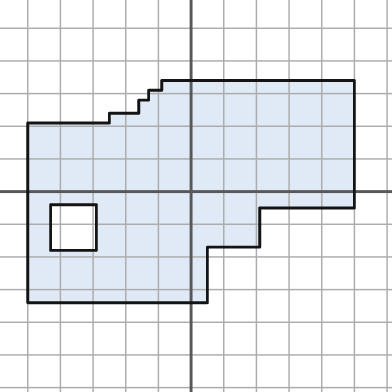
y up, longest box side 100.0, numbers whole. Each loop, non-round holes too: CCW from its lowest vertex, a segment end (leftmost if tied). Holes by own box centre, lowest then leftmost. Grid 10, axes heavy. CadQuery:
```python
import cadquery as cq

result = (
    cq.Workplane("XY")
    .moveTo(-50.0, -34.0)
    .lineTo(5.0, -34.0)
    .lineTo(5.0, -17.0)
    .lineTo(21.0, -17.0)
    .lineTo(21.0, -5.0)
    .lineTo(50.0, -5.0)
    .lineTo(50.0, 34.0)
    .lineTo(-9.0, 34.0)
    .lineTo(-9.0, 31.0)
    .lineTo(-13.0, 31.0)
    .lineTo(-13.0, 28.0)
    .lineTo(-16.0, 28.0)
    .lineTo(-16.0, 24.0)
    .lineTo(-25.0, 24.0)
    .lineTo(-25.0, 21.0)
    .lineTo(-50.0, 21.0)
    .close()
    .moveTo(-43.0, -18.0)
    .lineTo(-29.0, -18.0)
    .lineTo(-29.0, -4.0)
    .lineTo(-43.0, -4.0)
    .close()
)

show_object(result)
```